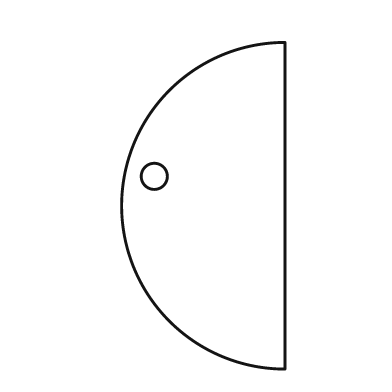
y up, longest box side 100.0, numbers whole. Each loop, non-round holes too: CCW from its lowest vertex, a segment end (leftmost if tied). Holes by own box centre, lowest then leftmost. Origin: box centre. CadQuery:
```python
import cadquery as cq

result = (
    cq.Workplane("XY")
    .moveTo(25.0, -50.0)
    .lineTo(25.0, 50.0)
    .threePointArc((-25.0, 0.0), (25.0, -50.0))
    .close()
    .moveTo(-15.0, 9.0)
    .circle(4.0)
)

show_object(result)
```